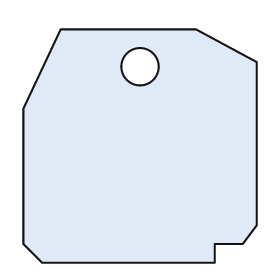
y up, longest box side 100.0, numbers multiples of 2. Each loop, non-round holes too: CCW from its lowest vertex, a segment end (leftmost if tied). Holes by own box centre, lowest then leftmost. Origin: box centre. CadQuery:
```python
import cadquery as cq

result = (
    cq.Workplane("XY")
    .moveTo(-42.0, -50.0)
    .lineTo(32.0, -50.0)
    .lineTo(32.0, -42.0)
    .lineTo(44.0, -42.0)
    .lineTo(50.0, -34.0)
    .lineTo(50.0, 36.0)
    .lineTo(24.0, 50.0)
    .lineTo(-34.0, 50.0)
    .lineTo(-50.0, 16.0)
    .lineTo(-50.0, -42.0)
    .close()
    .moveTo(0.0, 34.0)
    .circle(8.0)
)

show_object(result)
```